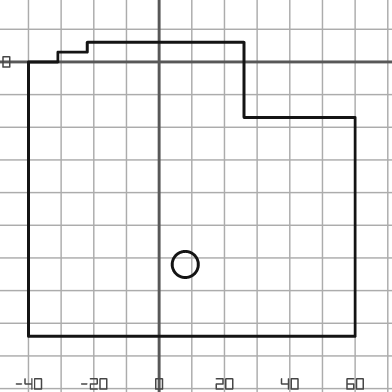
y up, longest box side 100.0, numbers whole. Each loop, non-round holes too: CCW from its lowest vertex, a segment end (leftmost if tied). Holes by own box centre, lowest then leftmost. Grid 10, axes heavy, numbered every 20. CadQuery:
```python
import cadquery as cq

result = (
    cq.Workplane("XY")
    .moveTo(-40.0, -84.0)
    .lineTo(60.0, -84.0)
    .lineTo(60.0, -17.0)
    .lineTo(26.0, -17.0)
    .lineTo(26.0, 6.0)
    .lineTo(-22.0, 6.0)
    .lineTo(-22.0, 3.0)
    .lineTo(-31.0, 3.0)
    .lineTo(-31.0, 0.0)
    .lineTo(-40.0, 0.0)
    .close()
    .moveTo(8.0, -62.0)
    .circle(4.0)
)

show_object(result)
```